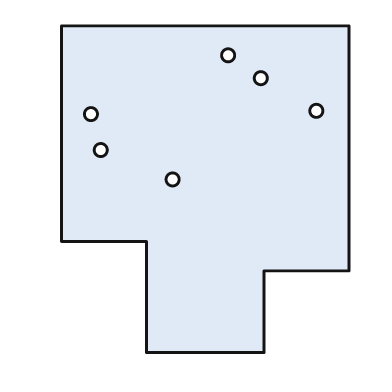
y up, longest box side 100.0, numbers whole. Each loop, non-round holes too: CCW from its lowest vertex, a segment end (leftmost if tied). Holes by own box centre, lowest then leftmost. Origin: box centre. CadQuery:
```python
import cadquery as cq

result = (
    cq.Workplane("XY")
    .moveTo(-18.0, -50.0)
    .lineTo(18.0, -50.0)
    .lineTo(18.0, -25.0)
    .lineTo(44.0, -25.0)
    .lineTo(44.0, 50.0)
    .lineTo(-44.0, 50.0)
    .lineTo(-44.0, -16.0)
    .lineTo(-18.0, -16.0)
    .close()
    .moveTo(-10.0, 3.0)
    .circle(2.0)
    .moveTo(-32.0, 12.0)
    .circle(2.0)
    .moveTo(-35.0, 23.0)
    .circle(2.0)
    .moveTo(34.0, 24.0)
    .circle(2.0)
    .moveTo(17.0, 34.0)
    .circle(2.0)
    .moveTo(7.0, 41.0)
    .circle(2.0)
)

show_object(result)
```